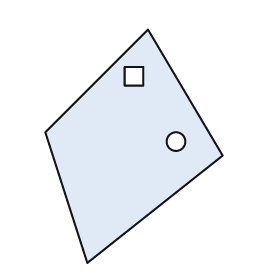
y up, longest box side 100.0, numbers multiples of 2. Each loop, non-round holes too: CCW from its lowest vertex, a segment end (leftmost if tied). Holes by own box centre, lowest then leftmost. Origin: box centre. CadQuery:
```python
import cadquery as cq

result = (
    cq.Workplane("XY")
    .moveTo(-20.0, -50.0)
    .lineTo(38.0, -4.0)
    .lineTo(6.0, 50.0)
    .lineTo(-38.0, 6.0)
    .close()
    .moveTo(18.0, 2.0)
    .circle(4.0)
    .moveTo(-4.0, 26.0)
    .lineTo(4.0, 26.0)
    .lineTo(4.0, 34.0)
    .lineTo(-4.0, 34.0)
    .close()
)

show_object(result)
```